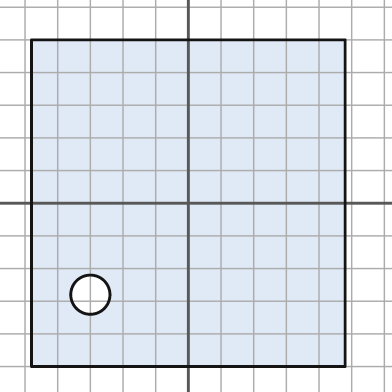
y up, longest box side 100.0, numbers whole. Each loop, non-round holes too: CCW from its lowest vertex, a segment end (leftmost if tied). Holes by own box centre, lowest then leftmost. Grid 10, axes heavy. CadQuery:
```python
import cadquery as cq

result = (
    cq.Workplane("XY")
    .moveTo(-48.0, -50.0)
    .lineTo(48.0, -50.0)
    .lineTo(48.0, 50.0)
    .lineTo(-48.0, 50.0)
    .close()
    .moveTo(-30.0, -28.0)
    .circle(6.0)
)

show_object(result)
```